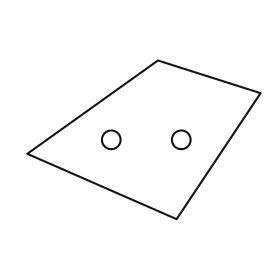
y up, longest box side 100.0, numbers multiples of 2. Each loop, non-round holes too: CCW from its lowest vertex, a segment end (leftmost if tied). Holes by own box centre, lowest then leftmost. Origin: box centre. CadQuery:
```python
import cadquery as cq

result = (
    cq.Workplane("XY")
    .moveTo(14.0, -34.0)
    .lineTo(50.0, 20.0)
    .lineTo(6.0, 34.0)
    .lineTo(-50.0, -6.0)
    .close()
    .moveTo(-14.0, 0.0)
    .circle(4.0)
    .moveTo(16.0, 0.0)
    .circle(4.0)
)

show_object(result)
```